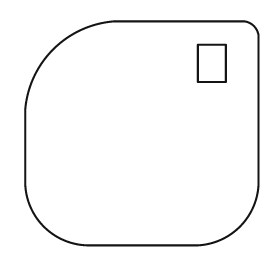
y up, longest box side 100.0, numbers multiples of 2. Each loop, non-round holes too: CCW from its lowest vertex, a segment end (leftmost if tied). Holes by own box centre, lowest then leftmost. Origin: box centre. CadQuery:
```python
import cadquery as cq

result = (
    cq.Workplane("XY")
    .moveTo(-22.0, -48.0)
    .lineTo(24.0, -48.0)
    .threePointArc((42.0, -40.0), (50.0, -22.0))
    .lineTo(50.0, 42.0)
    .threePointArc((48.0, 46.0), (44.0, 48.0))
    .lineTo(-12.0, 48.0)
    .threePointArc((-38.0, 36.0), (-50.0, 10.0))
    .lineTo(-50.0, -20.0)
    .threePointArc((-42.0, -40.0), (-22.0, -48.0))
    .close()
    .moveTo(24.0, 22.0)
    .lineTo(36.0, 22.0)
    .lineTo(36.0, 38.0)
    .lineTo(24.0, 38.0)
    .close()
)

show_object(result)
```